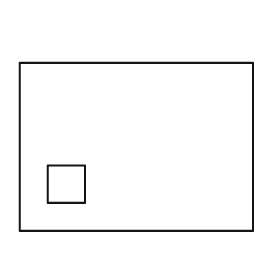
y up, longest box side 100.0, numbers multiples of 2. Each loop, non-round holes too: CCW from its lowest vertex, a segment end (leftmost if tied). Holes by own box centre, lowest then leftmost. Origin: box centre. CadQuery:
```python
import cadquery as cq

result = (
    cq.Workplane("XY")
    .moveTo(-50.0, -36.0)
    .lineTo(50.0, -36.0)
    .lineTo(50.0, 36.0)
    .lineTo(-50.0, 36.0)
    .close()
    .moveTo(-38.0, -24.0)
    .lineTo(-22.0, -24.0)
    .lineTo(-22.0, -8.0)
    .lineTo(-38.0, -8.0)
    .close()
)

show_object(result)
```